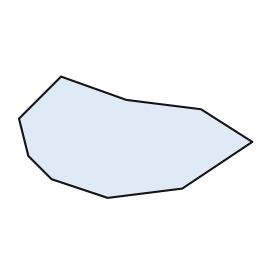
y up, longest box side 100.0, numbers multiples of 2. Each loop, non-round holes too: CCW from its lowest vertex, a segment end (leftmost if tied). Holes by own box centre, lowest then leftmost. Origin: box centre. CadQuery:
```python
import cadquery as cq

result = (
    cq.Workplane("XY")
    .moveTo(-12.0, -26.0)
    .lineTo(20.0, -22.0)
    .lineTo(50.0, -2.0)
    .lineTo(28.0, 12.0)
    .lineTo(-4.0, 16.0)
    .lineTo(-32.0, 26.0)
    .lineTo(-50.0, 8.0)
    .lineTo(-46.0, -8.0)
    .lineTo(-36.0, -18.0)
    .close()
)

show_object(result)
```